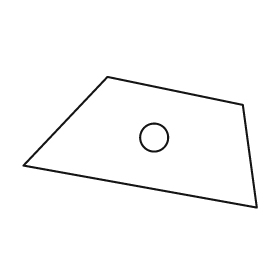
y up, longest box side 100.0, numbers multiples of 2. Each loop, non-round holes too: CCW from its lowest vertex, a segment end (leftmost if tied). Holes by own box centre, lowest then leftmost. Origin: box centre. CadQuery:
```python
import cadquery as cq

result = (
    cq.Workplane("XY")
    .moveTo(50.0, -28.0)
    .lineTo(44.0, 16.0)
    .lineTo(-14.0, 28.0)
    .lineTo(-50.0, -10.0)
    .close()
    .moveTo(6.0, 2.0)
    .circle(6.0)
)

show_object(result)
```